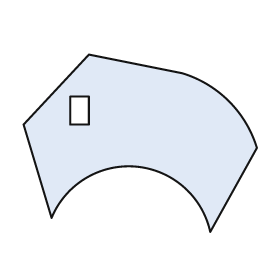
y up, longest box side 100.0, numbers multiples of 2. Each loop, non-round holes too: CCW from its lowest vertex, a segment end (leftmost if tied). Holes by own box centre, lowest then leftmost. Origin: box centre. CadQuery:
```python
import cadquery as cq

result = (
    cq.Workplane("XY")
    .moveTo(30.0, -38.0)
    .lineTo(50.0, -2.0)
    .threePointArc((38.0, 18.0), (18.0, 30.0))
    .lineTo(-22.0, 38.0)
    .lineTo(-50.0, 8.0)
    .lineTo(-38.0, -32.0)
    .threePointArc((-2.0, -10.0), (30.0, -38.0))
    .close()
    .moveTo(-30.0, 8.0)
    .lineTo(-22.0, 8.0)
    .lineTo(-22.0, 20.0)
    .lineTo(-30.0, 20.0)
    .close()
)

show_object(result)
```